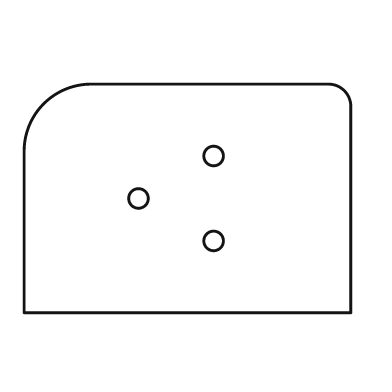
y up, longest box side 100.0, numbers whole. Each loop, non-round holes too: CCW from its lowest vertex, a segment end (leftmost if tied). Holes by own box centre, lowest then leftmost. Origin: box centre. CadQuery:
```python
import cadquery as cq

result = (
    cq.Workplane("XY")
    .moveTo(-50.0, -35.0)
    .lineTo(50.0, -35.0)
    .lineTo(50.0, 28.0)
    .threePointArc((48.0, 33.0), (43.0, 35.0))
    .lineTo(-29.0, 35.0)
    .threePointArc((-44.0, 29.0), (-50.0, 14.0))
    .close()
    .moveTo(8.0, -13.0)
    .circle(3.0)
    .moveTo(-15.0, 0.0)
    .circle(3.0)
    .moveTo(8.0, 13.0)
    .circle(3.0)
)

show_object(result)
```